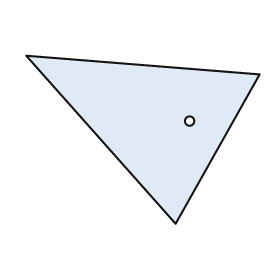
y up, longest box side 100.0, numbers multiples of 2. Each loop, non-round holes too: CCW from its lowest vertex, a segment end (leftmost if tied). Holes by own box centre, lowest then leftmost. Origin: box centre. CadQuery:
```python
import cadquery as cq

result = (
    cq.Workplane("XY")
    .moveTo(14.0, -36.0)
    .lineTo(50.0, 28.0)
    .lineTo(-50.0, 36.0)
    .close()
    .moveTo(20.0, 8.0)
    .circle(2.0)
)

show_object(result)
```